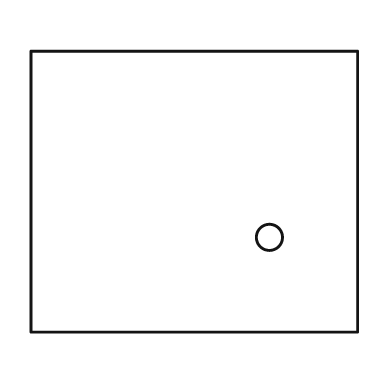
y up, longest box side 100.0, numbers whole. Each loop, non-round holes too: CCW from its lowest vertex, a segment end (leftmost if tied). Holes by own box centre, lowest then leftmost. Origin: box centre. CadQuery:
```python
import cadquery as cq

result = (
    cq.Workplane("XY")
    .moveTo(-50.0, -43.0)
    .lineTo(50.0, -43.0)
    .lineTo(50.0, 43.0)
    .lineTo(-50.0, 43.0)
    .close()
    .moveTo(23.0, -14.0)
    .circle(4.0)
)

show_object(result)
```